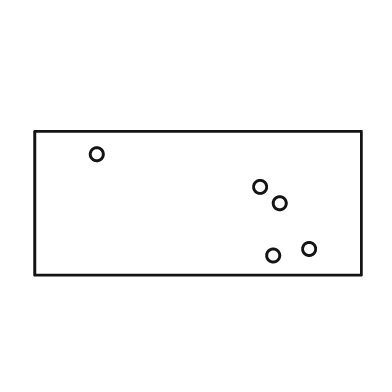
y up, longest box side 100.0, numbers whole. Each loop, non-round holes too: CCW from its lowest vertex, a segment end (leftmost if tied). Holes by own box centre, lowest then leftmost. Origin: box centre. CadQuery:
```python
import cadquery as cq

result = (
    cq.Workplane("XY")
    .moveTo(-50.0, -22.0)
    .lineTo(50.0, -22.0)
    .lineTo(50.0, 22.0)
    .lineTo(-50.0, 22.0)
    .close()
    .moveTo(23.0, -16.0)
    .circle(2.0)
    .moveTo(34.0, -14.0)
    .circle(2.0)
    .moveTo(25.0, 0.0)
    .circle(2.0)
    .moveTo(19.0, 5.0)
    .circle(2.0)
    .moveTo(-31.0, 15.0)
    .circle(2.0)
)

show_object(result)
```